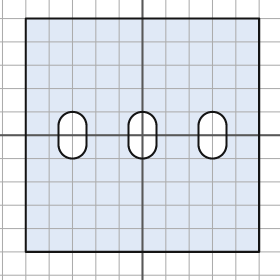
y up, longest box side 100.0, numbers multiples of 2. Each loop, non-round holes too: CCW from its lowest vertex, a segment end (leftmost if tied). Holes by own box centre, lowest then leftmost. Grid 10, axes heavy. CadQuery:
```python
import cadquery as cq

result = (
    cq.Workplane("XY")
    .moveTo(-50.0, -50.0)
    .lineTo(50.0, -50.0)
    .lineTo(50.0, 50.0)
    .lineTo(-50.0, 50.0)
    .close()
    .moveTo(-36.0, -4.0)
    .threePointArc((-30.0, -10.0), (-24.0, -4.0))
    .lineTo(-24.0, 4.0)
    .threePointArc((-30.0, 10.0), (-36.0, 4.0))
    .close()
    .moveTo(-6.0, -4.0)
    .threePointArc((0.0, -10.0), (6.0, -4.0))
    .lineTo(6.0, 4.0)
    .threePointArc((0.0, 10.0), (-6.0, 4.0))
    .close()
    .moveTo(24.0, -4.0)
    .threePointArc((30.0, -10.0), (36.0, -4.0))
    .lineTo(36.0, 4.0)
    .threePointArc((30.0, 10.0), (24.0, 4.0))
    .close()
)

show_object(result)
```